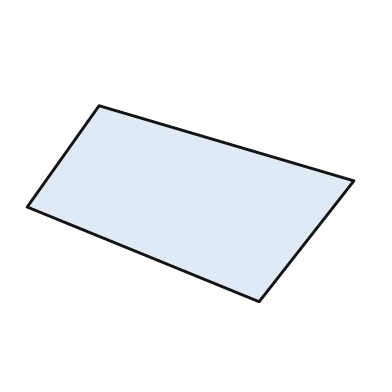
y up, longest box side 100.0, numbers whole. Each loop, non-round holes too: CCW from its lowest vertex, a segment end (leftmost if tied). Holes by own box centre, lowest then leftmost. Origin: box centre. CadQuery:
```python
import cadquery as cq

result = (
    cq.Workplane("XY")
    .moveTo(21.0, -30.0)
    .lineTo(50.0, 7.0)
    .lineTo(-28.0, 30.0)
    .lineTo(-50.0, -1.0)
    .close()
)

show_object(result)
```